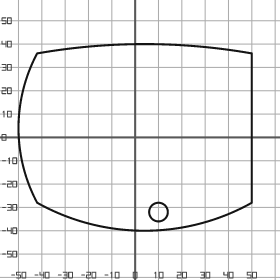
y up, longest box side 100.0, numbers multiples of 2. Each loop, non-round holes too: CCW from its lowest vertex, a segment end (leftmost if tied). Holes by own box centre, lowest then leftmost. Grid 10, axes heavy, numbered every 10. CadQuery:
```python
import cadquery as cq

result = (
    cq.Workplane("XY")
    .moveTo(-42.0, -28.0)
    .threePointArc((4.0, -40.0), (50.0, -28.0))
    .lineTo(50.0, 36.0)
    .threePointArc((4.0, 40.0), (-42.0, 36.0))
    .threePointArc((-50.0, 4.0), (-42.0, -28.0))
    .close()
    .moveTo(10.0, -32.0)
    .circle(4.0)
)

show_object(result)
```